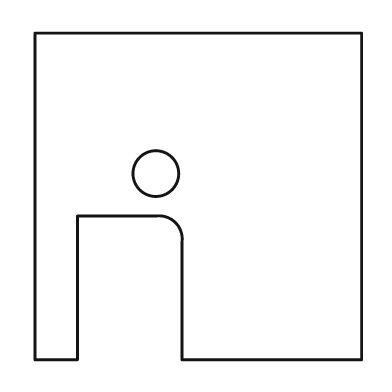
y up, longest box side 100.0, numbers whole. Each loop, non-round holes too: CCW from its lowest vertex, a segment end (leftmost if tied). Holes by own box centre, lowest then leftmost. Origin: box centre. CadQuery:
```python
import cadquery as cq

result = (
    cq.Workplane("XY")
    .moveTo(-50.0, -50.0)
    .lineTo(-37.0, -50.0)
    .lineTo(-37.0, -6.0)
    .lineTo(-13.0, -6.0)
    .threePointArc((-7.0, -8.0), (-5.0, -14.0))
    .lineTo(-5.0, -50.0)
    .lineTo(50.0, -50.0)
    .lineTo(50.0, 50.0)
    .lineTo(-50.0, 50.0)
    .close()
    .moveTo(-13.0, 7.0)
    .circle(7.0)
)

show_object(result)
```